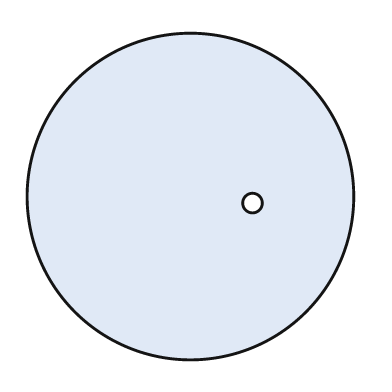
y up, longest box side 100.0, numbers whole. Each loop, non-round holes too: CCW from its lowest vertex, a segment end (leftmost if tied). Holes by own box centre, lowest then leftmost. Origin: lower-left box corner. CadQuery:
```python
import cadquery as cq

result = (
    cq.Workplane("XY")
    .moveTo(50.0, 50.0)
    .circle(50.0)
    .moveTo(69.0, 48.0)
    .circle(3.0)
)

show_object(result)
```